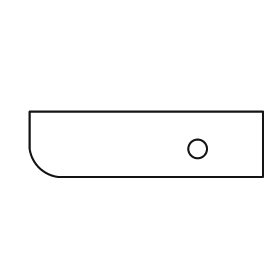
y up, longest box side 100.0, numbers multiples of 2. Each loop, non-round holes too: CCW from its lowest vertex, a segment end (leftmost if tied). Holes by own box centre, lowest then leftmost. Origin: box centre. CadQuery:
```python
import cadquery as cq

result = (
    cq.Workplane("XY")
    .moveTo(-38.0, -14.0)
    .lineTo(50.0, -14.0)
    .lineTo(50.0, 14.0)
    .lineTo(-50.0, 14.0)
    .lineTo(-50.0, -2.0)
    .threePointArc((-46.0, -10.0), (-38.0, -14.0))
    .close()
    .moveTo(22.0, -2.0)
    .circle(4.0)
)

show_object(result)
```